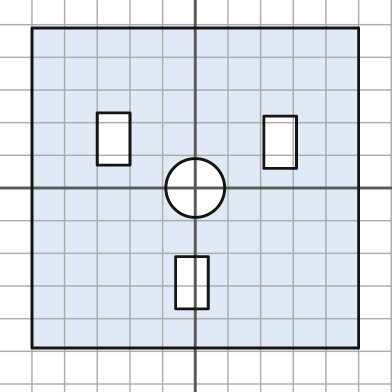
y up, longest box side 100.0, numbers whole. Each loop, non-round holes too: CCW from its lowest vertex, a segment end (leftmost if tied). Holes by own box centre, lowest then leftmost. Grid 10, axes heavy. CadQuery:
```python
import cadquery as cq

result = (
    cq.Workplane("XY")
    .moveTo(-50.0, -49.0)
    .lineTo(50.0, -49.0)
    .lineTo(50.0, 49.0)
    .lineTo(-50.0, 49.0)
    .close()
    .moveTo(-6.0, -37.0)
    .lineTo(4.0, -37.0)
    .lineTo(4.0, -21.0)
    .lineTo(-6.0, -21.0)
    .close()
    .moveTo(0.0, 0.0)
    .circle(9.0)
    .moveTo(21.0, 6.0)
    .lineTo(31.0, 6.0)
    .lineTo(31.0, 22.0)
    .lineTo(21.0, 22.0)
    .close()
    .moveTo(-30.0, 7.0)
    .lineTo(-20.0, 7.0)
    .lineTo(-20.0, 23.0)
    .lineTo(-30.0, 23.0)
    .close()
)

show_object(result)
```